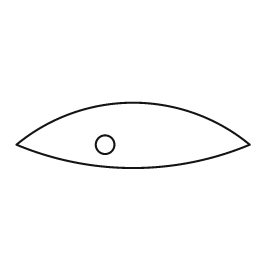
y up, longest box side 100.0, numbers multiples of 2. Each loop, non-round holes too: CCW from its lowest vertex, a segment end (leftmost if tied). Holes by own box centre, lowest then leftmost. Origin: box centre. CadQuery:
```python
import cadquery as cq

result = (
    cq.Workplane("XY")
    .moveTo(-50.0, -4.0)
    .threePointArc((0.0, -14.0), (50.0, -4.0))
    .threePointArc((0.0, 14.0), (-50.0, -4.0))
    .close()
    .moveTo(-12.0, -4.0)
    .circle(4.0)
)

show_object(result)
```